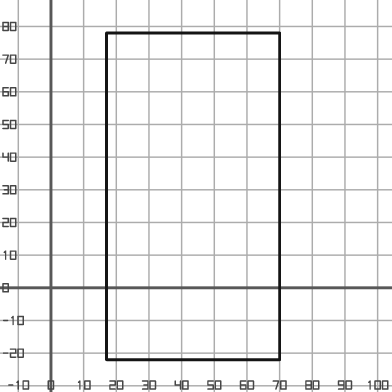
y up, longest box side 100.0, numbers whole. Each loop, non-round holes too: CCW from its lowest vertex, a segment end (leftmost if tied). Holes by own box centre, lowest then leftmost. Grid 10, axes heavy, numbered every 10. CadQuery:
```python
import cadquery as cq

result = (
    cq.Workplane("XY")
    .moveTo(17.0, -22.0)
    .lineTo(70.0, -22.0)
    .lineTo(70.0, 78.0)
    .lineTo(17.0, 78.0)
    .close()
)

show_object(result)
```